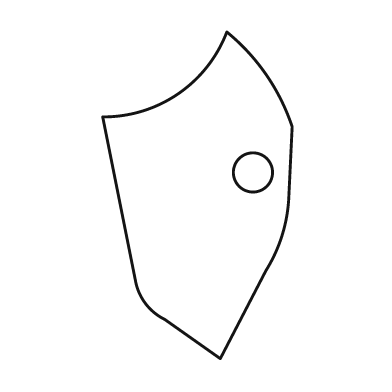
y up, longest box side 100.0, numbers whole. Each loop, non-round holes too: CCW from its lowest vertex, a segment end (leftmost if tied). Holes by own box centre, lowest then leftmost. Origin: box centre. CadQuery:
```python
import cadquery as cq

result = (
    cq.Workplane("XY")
    .moveTo(7.0, -50.0)
    .lineTo(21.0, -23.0)
    .threePointArc((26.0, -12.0), (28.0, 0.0))
    .lineTo(29.0, 21.0)
    .threePointArc((21.0, 37.0), (9.0, 50.0))
    .threePointArc((-6.0, 31.0), (-29.0, 24.0))
    .lineTo(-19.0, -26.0)
    .threePointArc((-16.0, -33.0), (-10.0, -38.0))
    .close()
    .moveTo(17.0, 7.0)
    .circle(6.0)
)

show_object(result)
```